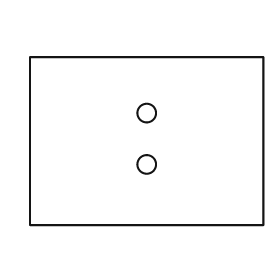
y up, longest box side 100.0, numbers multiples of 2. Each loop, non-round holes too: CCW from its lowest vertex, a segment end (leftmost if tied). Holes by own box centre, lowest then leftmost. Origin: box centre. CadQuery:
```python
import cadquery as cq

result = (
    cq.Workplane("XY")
    .moveTo(-50.0, -36.0)
    .lineTo(50.0, -36.0)
    .lineTo(50.0, 36.0)
    .lineTo(-50.0, 36.0)
    .close()
    .moveTo(0.0, -10.0)
    .circle(4.0)
    .moveTo(0.0, 12.0)
    .circle(4.0)
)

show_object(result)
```